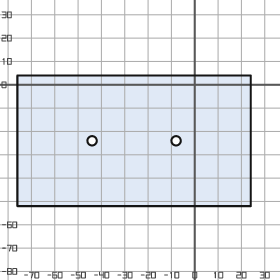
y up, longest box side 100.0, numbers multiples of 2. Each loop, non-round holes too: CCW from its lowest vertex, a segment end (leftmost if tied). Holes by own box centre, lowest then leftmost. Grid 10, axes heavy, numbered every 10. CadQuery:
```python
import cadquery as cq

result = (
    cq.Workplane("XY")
    .moveTo(-76.0, -52.0)
    .lineTo(24.0, -52.0)
    .lineTo(24.0, 4.0)
    .lineTo(-76.0, 4.0)
    .close()
    .moveTo(-44.0, -24.0)
    .circle(2.0)
    .moveTo(-8.0, -24.0)
    .circle(2.0)
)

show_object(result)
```